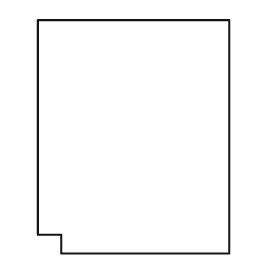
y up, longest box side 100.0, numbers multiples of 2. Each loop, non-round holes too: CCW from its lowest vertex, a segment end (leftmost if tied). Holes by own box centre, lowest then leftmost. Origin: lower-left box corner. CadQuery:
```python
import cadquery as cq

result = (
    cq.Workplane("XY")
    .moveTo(10.0, 0.0)
    .lineTo(82.0, 0.0)
    .lineTo(82.0, 100.0)
    .lineTo(0.0, 100.0)
    .lineTo(0.0, 8.0)
    .lineTo(10.0, 8.0)
    .close()
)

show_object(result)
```